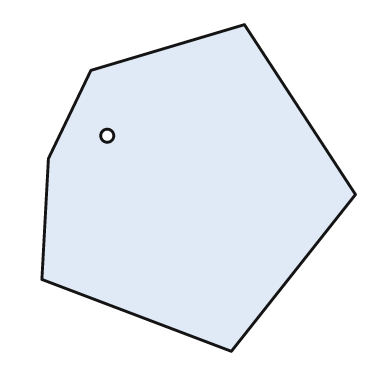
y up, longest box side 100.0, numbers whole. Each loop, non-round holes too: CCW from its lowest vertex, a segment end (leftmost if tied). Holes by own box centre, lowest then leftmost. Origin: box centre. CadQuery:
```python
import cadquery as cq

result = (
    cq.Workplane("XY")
    .moveTo(10.0, -50.0)
    .lineTo(48.0, -2.0)
    .lineTo(14.0, 50.0)
    .lineTo(-33.0, 36.0)
    .lineTo(-46.0, 9.0)
    .lineTo(-48.0, -28.0)
    .close()
    .moveTo(-28.0, 16.0)
    .circle(2.0)
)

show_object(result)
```